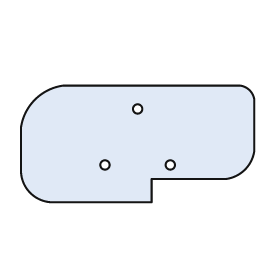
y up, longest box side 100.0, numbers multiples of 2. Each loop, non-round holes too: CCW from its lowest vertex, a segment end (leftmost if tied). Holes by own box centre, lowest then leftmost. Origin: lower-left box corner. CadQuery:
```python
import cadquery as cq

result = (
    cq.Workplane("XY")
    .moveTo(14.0, 0.0)
    .lineTo(56.0, 0.0)
    .lineTo(56.0, 10.0)
    .lineTo(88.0, 10.0)
    .threePointArc((96.0, 14.0), (100.0, 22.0))
    .lineTo(100.0, 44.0)
    .threePointArc((98.0, 48.0), (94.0, 50.0))
    .lineTo(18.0, 50.0)
    .threePointArc((6.0, 44.0), (0.0, 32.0))
    .lineTo(0.0, 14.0)
    .threePointArc((4.0, 4.0), (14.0, 0.0))
    .close()
    .moveTo(36.0, 16.0)
    .circle(2.0)
    .moveTo(64.0, 16.0)
    .circle(2.0)
    .moveTo(50.0, 40.0)
    .circle(2.0)
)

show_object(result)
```